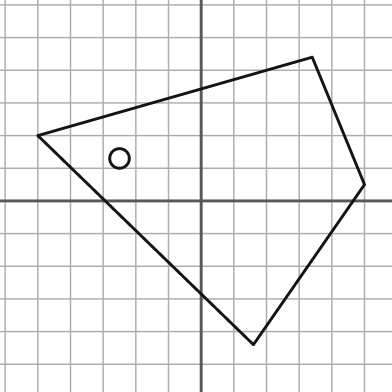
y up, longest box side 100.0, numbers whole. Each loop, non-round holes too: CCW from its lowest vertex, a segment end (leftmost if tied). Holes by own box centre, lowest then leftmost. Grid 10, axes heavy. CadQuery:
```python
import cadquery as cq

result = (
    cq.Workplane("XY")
    .moveTo(16.0, -44.0)
    .lineTo(50.0, 5.0)
    .lineTo(34.0, 44.0)
    .lineTo(-50.0, 20.0)
    .close()
    .moveTo(-25.0, 13.0)
    .circle(3.0)
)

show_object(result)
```